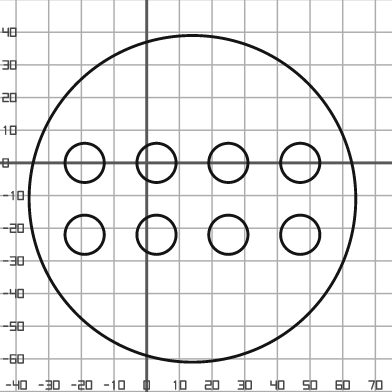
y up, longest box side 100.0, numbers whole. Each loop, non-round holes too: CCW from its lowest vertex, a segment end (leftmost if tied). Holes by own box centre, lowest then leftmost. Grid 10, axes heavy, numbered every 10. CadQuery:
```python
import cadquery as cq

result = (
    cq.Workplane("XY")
    .moveTo(14.0, -11.0)
    .circle(50.0)
    .moveTo(-19.0, -22.0)
    .circle(6.0)
    .moveTo(3.0, -22.0)
    .circle(6.0)
    .moveTo(25.0, -22.0)
    .circle(6.0)
    .moveTo(47.0, -22.0)
    .circle(6.0)
    .moveTo(-19.0, 0.0)
    .circle(6.0)
    .moveTo(3.0, 0.0)
    .circle(6.0)
    .moveTo(25.0, 0.0)
    .circle(6.0)
    .moveTo(47.0, 0.0)
    .circle(6.0)
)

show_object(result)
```